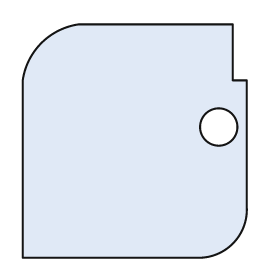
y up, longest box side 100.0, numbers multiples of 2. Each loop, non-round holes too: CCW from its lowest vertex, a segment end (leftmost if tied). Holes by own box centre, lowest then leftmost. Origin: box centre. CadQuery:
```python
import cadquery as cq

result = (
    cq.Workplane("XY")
    .moveTo(-48.0, -50.0)
    .lineTo(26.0, -50.0)
    .threePointArc((42.0, -44.0), (48.0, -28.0))
    .lineTo(48.0, 26.0)
    .lineTo(42.0, 26.0)
    .lineTo(42.0, 50.0)
    .lineTo(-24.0, 50.0)
    .threePointArc((-40.0, 42.0), (-48.0, 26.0))
    .close()
    .moveTo(36.0, 6.0)
    .circle(8.0)
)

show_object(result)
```